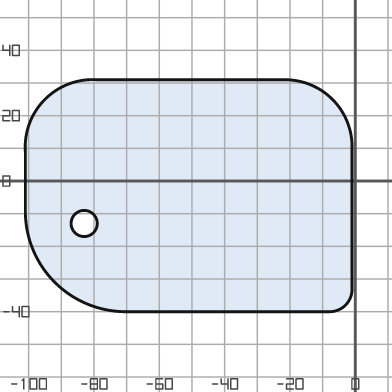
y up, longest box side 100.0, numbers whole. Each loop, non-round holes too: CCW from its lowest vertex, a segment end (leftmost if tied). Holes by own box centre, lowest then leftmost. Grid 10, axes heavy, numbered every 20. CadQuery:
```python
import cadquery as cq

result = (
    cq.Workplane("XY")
    .moveTo(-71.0, -40.0)
    .lineTo(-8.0, -40.0)
    .threePointArc((-3.0, -38.0), (-1.0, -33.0))
    .lineTo(-1.0, 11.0)
    .threePointArc((-7.0, 25.0), (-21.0, 31.0))
    .lineTo(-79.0, 31.0)
    .threePointArc((-95.0, 25.0), (-101.0, 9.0))
    .lineTo(-101.0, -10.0)
    .threePointArc((-92.0, -31.0), (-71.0, -40.0))
    .close()
    .moveTo(-83.0, -13.0)
    .circle(4.0)
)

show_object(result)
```